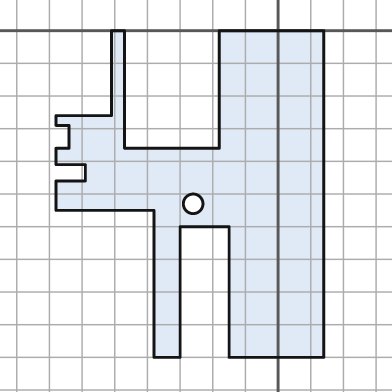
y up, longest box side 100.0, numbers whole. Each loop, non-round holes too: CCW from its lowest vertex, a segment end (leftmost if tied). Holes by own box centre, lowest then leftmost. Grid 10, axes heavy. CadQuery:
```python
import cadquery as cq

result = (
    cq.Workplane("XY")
    .moveTo(-38.0, -100.0)
    .lineTo(-30.0, -100.0)
    .lineTo(-30.0, -60.0)
    .lineTo(-15.0, -60.0)
    .lineTo(-15.0, -100.0)
    .lineTo(14.0, -100.0)
    .lineTo(14.0, 0.0)
    .lineTo(-18.0, 0.0)
    .lineTo(-18.0, -36.0)
    .lineTo(-47.0, -36.0)
    .lineTo(-47.0, 0.0)
    .lineTo(-51.0, 0.0)
    .lineTo(-51.0, -26.0)
    .lineTo(-68.0, -26.0)
    .lineTo(-68.0, -29.0)
    .lineTo(-64.0, -29.0)
    .lineTo(-64.0, -36.0)
    .lineTo(-68.0, -36.0)
    .lineTo(-68.0, -41.0)
    .lineTo(-59.0, -41.0)
    .lineTo(-59.0, -46.0)
    .lineTo(-68.0, -46.0)
    .lineTo(-68.0, -55.0)
    .lineTo(-38.0, -55.0)
    .close()
    .moveTo(-26.0, -53.0)
    .circle(3.0)
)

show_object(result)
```